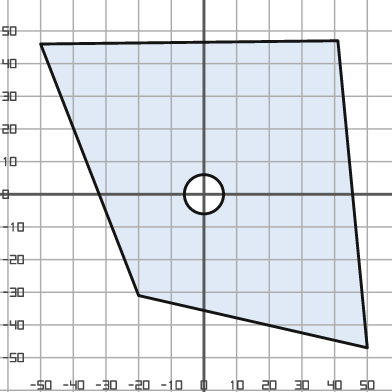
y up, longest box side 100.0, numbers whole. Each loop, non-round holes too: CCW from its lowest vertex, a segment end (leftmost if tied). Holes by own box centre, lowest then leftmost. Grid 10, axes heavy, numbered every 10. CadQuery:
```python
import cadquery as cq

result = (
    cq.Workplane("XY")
    .moveTo(50.0, -47.0)
    .lineTo(41.0, 47.0)
    .lineTo(-50.0, 46.0)
    .lineTo(-20.0, -31.0)
    .close()
    .moveTo(0.0, 0.0)
    .circle(6.0)
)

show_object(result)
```